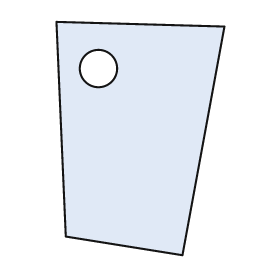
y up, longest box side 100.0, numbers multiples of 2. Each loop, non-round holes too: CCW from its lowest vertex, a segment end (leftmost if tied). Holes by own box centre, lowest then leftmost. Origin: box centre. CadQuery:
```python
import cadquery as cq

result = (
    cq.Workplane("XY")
    .moveTo(18.0, -50.0)
    .lineTo(36.0, 48.0)
    .lineTo(-36.0, 50.0)
    .lineTo(-32.0, -42.0)
    .close()
    .moveTo(-18.0, 30.0)
    .circle(8.0)
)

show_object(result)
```